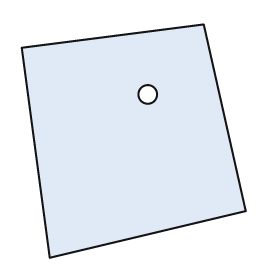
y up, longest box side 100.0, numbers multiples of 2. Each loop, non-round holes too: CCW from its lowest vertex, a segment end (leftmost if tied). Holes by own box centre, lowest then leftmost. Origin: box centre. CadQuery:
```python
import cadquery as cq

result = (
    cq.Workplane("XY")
    .moveTo(-36.0, -50.0)
    .lineTo(48.0, -30.0)
    .lineTo(30.0, 50.0)
    .lineTo(-48.0, 40.0)
    .close()
    .moveTo(6.0, 20.0)
    .circle(4.0)
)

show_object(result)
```